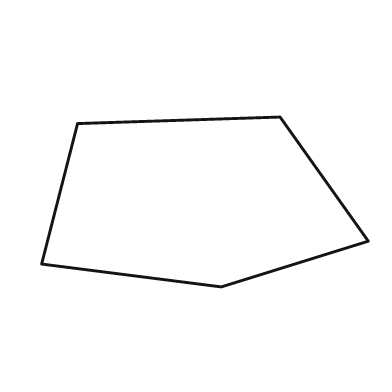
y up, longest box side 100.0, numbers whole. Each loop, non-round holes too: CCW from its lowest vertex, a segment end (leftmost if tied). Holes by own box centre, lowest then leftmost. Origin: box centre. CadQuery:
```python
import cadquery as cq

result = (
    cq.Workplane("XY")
    .moveTo(5.0, -26.0)
    .lineTo(50.0, -12.0)
    .lineTo(23.0, 26.0)
    .lineTo(-39.0, 24.0)
    .lineTo(-50.0, -19.0)
    .close()
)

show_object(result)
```